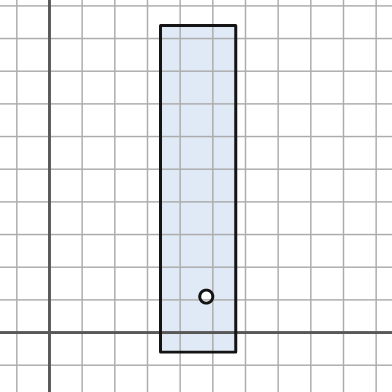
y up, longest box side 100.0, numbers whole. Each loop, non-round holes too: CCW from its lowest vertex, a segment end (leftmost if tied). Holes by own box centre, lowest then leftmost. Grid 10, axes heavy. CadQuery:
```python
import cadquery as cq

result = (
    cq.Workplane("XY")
    .moveTo(34.0, -6.0)
    .lineTo(57.0, -6.0)
    .lineTo(57.0, 94.0)
    .lineTo(34.0, 94.0)
    .close()
    .moveTo(48.0, 11.0)
    .circle(2.0)
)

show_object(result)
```